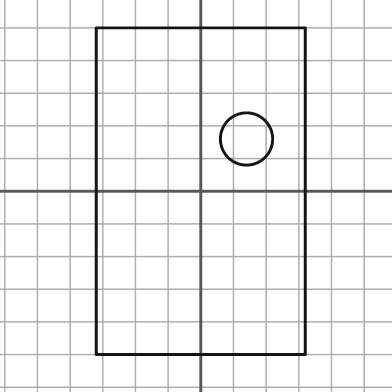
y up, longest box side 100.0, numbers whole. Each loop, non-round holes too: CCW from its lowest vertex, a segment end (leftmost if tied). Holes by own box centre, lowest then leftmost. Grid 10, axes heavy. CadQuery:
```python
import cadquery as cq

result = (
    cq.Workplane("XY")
    .moveTo(-32.0, -50.0)
    .lineTo(32.0, -50.0)
    .lineTo(32.0, 50.0)
    .lineTo(-32.0, 50.0)
    .close()
    .moveTo(14.0, 16.0)
    .circle(8.0)
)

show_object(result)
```